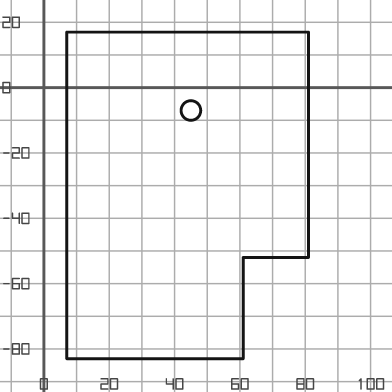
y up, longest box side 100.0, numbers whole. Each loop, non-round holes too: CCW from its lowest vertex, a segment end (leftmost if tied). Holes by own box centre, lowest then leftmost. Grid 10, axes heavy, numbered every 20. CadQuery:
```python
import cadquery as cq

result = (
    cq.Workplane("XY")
    .moveTo(7.0, -83.0)
    .lineTo(61.0, -83.0)
    .lineTo(61.0, -52.0)
    .lineTo(81.0, -52.0)
    .lineTo(81.0, 17.0)
    .lineTo(7.0, 17.0)
    .close()
    .moveTo(45.0, -7.0)
    .circle(3.0)
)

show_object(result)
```